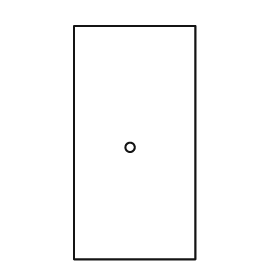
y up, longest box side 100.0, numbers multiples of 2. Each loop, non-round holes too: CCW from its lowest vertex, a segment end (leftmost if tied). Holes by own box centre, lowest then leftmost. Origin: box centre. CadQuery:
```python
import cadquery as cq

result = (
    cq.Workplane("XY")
    .moveTo(-26.0, -50.0)
    .lineTo(26.0, -50.0)
    .lineTo(26.0, 50.0)
    .lineTo(-26.0, 50.0)
    .close()
    .moveTo(-2.0, -2.0)
    .circle(2.0)
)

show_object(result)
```